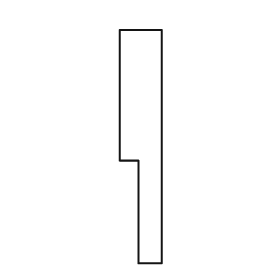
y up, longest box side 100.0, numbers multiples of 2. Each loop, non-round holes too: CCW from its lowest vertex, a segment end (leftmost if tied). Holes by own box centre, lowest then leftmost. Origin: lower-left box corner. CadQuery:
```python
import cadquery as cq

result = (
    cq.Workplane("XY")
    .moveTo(8.0, 0.0)
    .lineTo(18.0, 0.0)
    .lineTo(18.0, 100.0)
    .lineTo(0.0, 100.0)
    .lineTo(0.0, 44.0)
    .lineTo(8.0, 44.0)
    .close()
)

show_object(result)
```